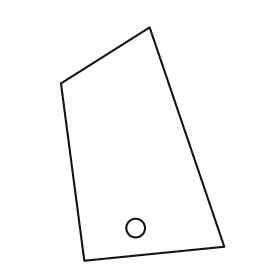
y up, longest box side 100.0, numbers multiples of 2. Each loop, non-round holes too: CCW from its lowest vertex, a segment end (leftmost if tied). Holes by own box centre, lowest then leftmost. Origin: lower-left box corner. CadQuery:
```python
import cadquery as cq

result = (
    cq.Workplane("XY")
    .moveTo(10.0, 0.0)
    .lineTo(70.0, 6.0)
    .lineTo(38.0, 100.0)
    .lineTo(0.0, 76.0)
    .close()
    .moveTo(32.0, 14.0)
    .circle(4.0)
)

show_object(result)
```